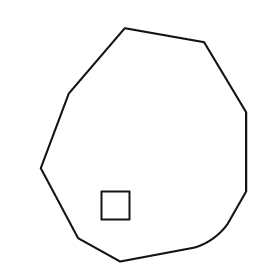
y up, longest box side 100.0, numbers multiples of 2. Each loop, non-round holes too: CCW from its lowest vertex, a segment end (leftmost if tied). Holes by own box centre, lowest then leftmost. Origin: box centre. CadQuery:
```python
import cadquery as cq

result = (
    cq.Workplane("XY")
    .moveTo(-10.0, -50.0)
    .lineTo(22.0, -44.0)
    .threePointArc((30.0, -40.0), (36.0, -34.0))
    .lineTo(44.0, -20.0)
    .lineTo(44.0, 14.0)
    .lineTo(26.0, 44.0)
    .lineTo(-8.0, 50.0)
    .lineTo(-32.0, 22.0)
    .lineTo(-44.0, -10.0)
    .lineTo(-28.0, -40.0)
    .close()
    .moveTo(-18.0, -32.0)
    .lineTo(-6.0, -32.0)
    .lineTo(-6.0, -20.0)
    .lineTo(-18.0, -20.0)
    .close()
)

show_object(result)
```